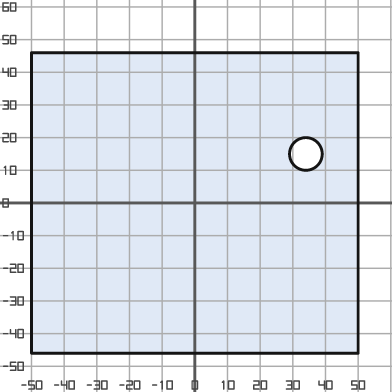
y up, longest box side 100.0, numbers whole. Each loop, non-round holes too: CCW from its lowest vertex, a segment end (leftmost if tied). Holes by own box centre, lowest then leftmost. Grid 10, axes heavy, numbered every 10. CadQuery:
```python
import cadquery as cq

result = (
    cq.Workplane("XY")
    .moveTo(-50.0, -46.0)
    .lineTo(50.0, -46.0)
    .lineTo(50.0, 46.0)
    .lineTo(-50.0, 46.0)
    .close()
    .moveTo(34.0, 15.0)
    .circle(5.0)
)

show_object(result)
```